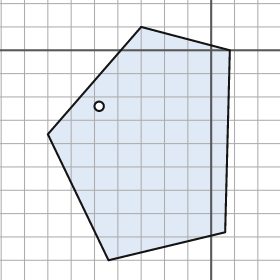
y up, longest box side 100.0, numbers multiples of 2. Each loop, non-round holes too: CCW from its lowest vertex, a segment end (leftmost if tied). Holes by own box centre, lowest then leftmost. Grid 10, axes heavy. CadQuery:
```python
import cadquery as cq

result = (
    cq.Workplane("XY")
    .moveTo(-44.0, -90.0)
    .lineTo(6.0, -78.0)
    .lineTo(8.0, 0.0)
    .lineTo(-30.0, 10.0)
    .lineTo(-70.0, -36.0)
    .close()
    .moveTo(-48.0, -24.0)
    .circle(2.0)
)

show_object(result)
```